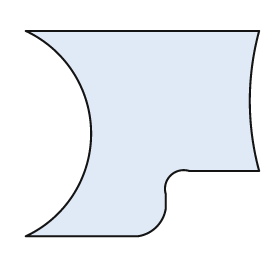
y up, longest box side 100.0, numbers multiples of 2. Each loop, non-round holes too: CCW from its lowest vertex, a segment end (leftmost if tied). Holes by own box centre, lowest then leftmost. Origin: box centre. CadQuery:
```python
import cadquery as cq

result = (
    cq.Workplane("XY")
    .moveTo(-50.0, -44.0)
    .lineTo(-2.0, -44.0)
    .threePointArc((6.0, -40.0), (10.0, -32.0))
    .lineTo(10.0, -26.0)
    .threePointArc((12.0, -18.0), (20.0, -16.0))
    .lineTo(50.0, -16.0)
    .threePointArc((46.0, 14.0), (50.0, 44.0))
    .lineTo(-50.0, 44.0)
    .threePointArc((-22.0, 0.0), (-50.0, -44.0))
    .close()
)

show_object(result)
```